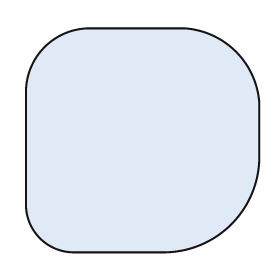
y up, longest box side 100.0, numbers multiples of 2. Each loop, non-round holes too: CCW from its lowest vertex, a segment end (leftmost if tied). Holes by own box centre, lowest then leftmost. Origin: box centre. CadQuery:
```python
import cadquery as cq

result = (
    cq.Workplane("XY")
    .moveTo(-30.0, -48.0)
    .lineTo(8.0, -48.0)
    .threePointArc((38.0, -36.0), (50.0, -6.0))
    .lineTo(50.0, 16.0)
    .threePointArc((40.0, 38.0), (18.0, 48.0))
    .lineTo(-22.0, 48.0)
    .threePointArc((-42.0, 40.0), (-50.0, 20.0))
    .lineTo(-50.0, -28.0)
    .threePointArc((-44.0, -42.0), (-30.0, -48.0))
    .close()
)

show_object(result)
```